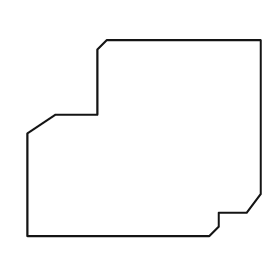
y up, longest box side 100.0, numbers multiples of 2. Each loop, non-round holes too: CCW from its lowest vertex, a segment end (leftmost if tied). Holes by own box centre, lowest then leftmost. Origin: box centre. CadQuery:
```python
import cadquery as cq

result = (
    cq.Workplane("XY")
    .moveTo(-50.0, -42.0)
    .lineTo(28.0, -42.0)
    .lineTo(32.0, -38.0)
    .lineTo(32.0, -32.0)
    .lineTo(44.0, -32.0)
    .lineTo(50.0, -24.0)
    .lineTo(50.0, 42.0)
    .lineTo(-16.0, 42.0)
    .lineTo(-20.0, 38.0)
    .lineTo(-20.0, 10.0)
    .lineTo(-38.0, 10.0)
    .lineTo(-50.0, 2.0)
    .close()
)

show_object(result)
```